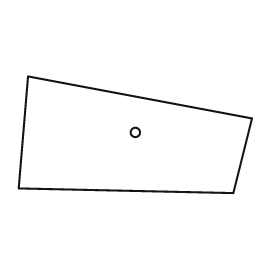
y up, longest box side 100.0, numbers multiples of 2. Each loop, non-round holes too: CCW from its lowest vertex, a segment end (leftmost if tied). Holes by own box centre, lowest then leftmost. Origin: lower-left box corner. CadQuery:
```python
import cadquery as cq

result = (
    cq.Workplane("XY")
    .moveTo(92.0, 0.0)
    .lineTo(100.0, 32.0)
    .lineTo(4.0, 50.0)
    .lineTo(0.0, 2.0)
    .close()
    .moveTo(50.0, 26.0)
    .circle(2.0)
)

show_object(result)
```